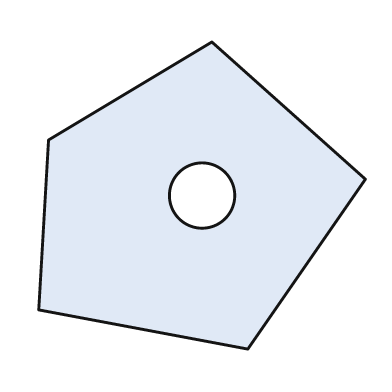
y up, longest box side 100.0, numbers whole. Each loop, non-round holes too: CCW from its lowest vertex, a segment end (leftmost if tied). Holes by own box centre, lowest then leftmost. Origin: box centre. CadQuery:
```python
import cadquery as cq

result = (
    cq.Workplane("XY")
    .moveTo(14.0, -47.0)
    .lineTo(50.0, 5.0)
    .lineTo(3.0, 47.0)
    .lineTo(-47.0, 17.0)
    .lineTo(-50.0, -35.0)
    .close()
    .moveTo(0.0, 0.0)
    .circle(10.0)
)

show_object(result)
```